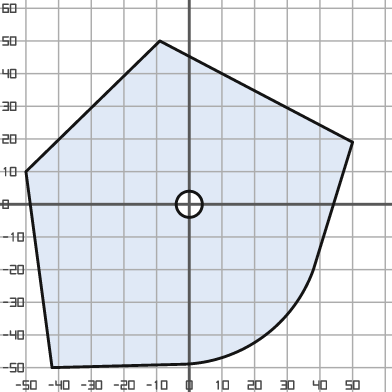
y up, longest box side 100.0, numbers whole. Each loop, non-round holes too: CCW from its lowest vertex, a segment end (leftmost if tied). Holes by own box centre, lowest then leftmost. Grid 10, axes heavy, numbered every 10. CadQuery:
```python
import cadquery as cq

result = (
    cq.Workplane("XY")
    .moveTo(-42.0, -50.0)
    .lineTo(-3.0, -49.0)
    .threePointArc((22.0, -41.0), (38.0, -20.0))
    .lineTo(50.0, 19.0)
    .lineTo(-9.0, 50.0)
    .lineTo(-50.0, 10.0)
    .close()
    .moveTo(0.0, 0.0)
    .circle(4.0)
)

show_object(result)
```